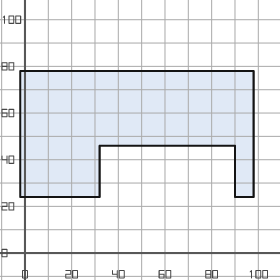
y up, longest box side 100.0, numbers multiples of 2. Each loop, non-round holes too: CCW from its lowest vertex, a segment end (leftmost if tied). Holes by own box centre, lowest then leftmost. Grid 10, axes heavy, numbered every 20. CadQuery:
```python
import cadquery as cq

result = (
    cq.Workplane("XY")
    .moveTo(-2.0, 24.0)
    .lineTo(32.0, 24.0)
    .lineTo(32.0, 46.0)
    .lineTo(90.0, 46.0)
    .lineTo(90.0, 24.0)
    .lineTo(98.0, 24.0)
    .lineTo(98.0, 78.0)
    .lineTo(-2.0, 78.0)
    .close()
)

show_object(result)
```